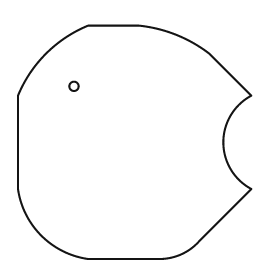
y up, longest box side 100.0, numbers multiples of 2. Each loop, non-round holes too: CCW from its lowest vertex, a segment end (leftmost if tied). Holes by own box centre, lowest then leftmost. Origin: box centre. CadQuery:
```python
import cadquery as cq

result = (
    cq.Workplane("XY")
    .moveTo(-20.0, -50.0)
    .lineTo(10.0, -50.0)
    .threePointArc((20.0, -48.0), (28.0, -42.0))
    .lineTo(50.0, -20.0)
    .threePointArc((38.0, 0.0), (50.0, 20.0))
    .lineTo(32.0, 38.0)
    .threePointArc((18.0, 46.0), (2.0, 50.0))
    .lineTo(-20.0, 50.0)
    .threePointArc((-38.0, 38.0), (-50.0, 20.0))
    .lineTo(-50.0, -20.0)
    .threePointArc((-40.0, -40.0), (-20.0, -50.0))
    .close()
    .moveTo(-26.0, 24.0)
    .circle(2.0)
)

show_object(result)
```